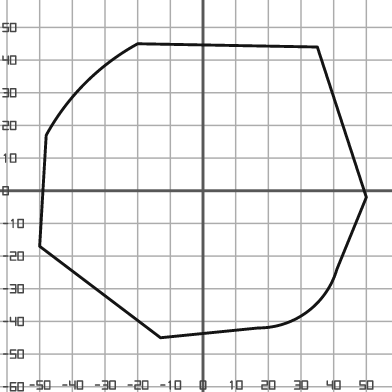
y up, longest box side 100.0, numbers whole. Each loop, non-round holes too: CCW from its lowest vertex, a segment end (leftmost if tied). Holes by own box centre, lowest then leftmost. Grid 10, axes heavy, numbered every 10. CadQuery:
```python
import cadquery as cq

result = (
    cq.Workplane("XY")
    .moveTo(-13.0, -45.0)
    .lineTo(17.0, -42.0)
    .threePointArc((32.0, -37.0), (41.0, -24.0))
    .lineTo(50.0, -2.0)
    .lineTo(35.0, 44.0)
    .lineTo(-20.0, 45.0)
    .threePointArc((-36.0, 33.0), (-48.0, 17.0))
    .lineTo(-50.0, -17.0)
    .close()
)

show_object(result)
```